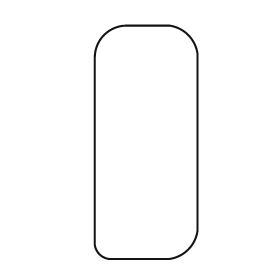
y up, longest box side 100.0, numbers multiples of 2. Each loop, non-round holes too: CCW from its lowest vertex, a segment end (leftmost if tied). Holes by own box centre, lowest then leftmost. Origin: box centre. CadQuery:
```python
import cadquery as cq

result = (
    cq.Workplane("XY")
    .moveTo(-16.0, -50.0)
    .lineTo(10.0, -50.0)
    .threePointArc((18.0, -46.0), (22.0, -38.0))
    .lineTo(22.0, 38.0)
    .threePointArc((18.0, 46.0), (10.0, 50.0))
    .lineTo(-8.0, 50.0)
    .threePointArc((-18.0, 46.0), (-22.0, 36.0))
    .lineTo(-22.0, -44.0)
    .threePointArc((-20.0, -48.0), (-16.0, -50.0))
    .close()
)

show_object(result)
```